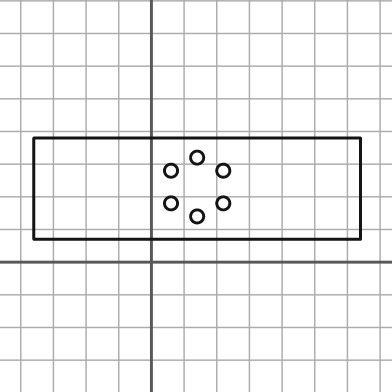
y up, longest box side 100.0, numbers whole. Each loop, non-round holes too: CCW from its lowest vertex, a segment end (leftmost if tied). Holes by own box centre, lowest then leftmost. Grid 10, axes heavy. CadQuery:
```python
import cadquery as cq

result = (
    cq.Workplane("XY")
    .moveTo(-36.0, 7.0)
    .lineTo(64.0, 7.0)
    .lineTo(64.0, 38.0)
    .lineTo(-36.0, 38.0)
    .close()
    .moveTo(14.0, 14.0)
    .circle(2.0)
    .moveTo(6.0, 18.0)
    .circle(2.0)
    .moveTo(22.0, 18.0)
    .circle(2.0)
    .moveTo(6.0, 28.0)
    .circle(2.0)
    .moveTo(22.0, 28.0)
    .circle(2.0)
    .moveTo(14.0, 32.0)
    .circle(2.0)
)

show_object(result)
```